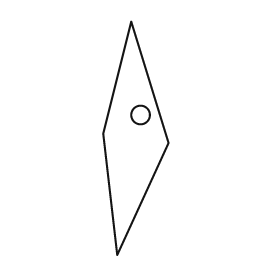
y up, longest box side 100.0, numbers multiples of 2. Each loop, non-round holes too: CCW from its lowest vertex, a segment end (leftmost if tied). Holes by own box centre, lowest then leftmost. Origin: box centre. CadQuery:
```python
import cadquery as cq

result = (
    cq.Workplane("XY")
    .moveTo(-8.0, -50.0)
    .lineTo(14.0, -2.0)
    .lineTo(-2.0, 50.0)
    .lineTo(-14.0, 2.0)
    .close()
    .moveTo(2.0, 10.0)
    .circle(4.0)
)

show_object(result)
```